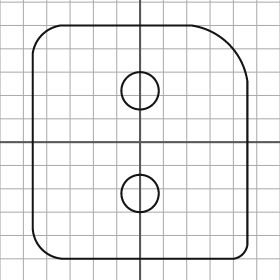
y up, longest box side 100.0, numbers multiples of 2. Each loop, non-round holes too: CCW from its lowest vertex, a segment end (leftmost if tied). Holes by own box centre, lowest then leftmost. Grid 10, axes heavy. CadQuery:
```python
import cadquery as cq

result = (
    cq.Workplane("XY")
    .moveTo(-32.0, -50.0)
    .lineTo(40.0, -50.0)
    .threePointArc((44.0, -48.0), (46.0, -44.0))
    .lineTo(46.0, 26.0)
    .threePointArc((38.0, 42.0), (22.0, 50.0))
    .lineTo(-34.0, 50.0)
    .threePointArc((-42.0, 46.0), (-46.0, 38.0))
    .lineTo(-46.0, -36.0)
    .threePointArc((-42.0, -46.0), (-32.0, -50.0))
    .close()
    .moveTo(0.0, -22.0)
    .circle(8.0)
    .moveTo(0.0, 22.0)
    .circle(8.0)
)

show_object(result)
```